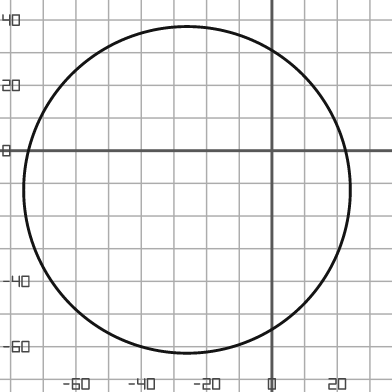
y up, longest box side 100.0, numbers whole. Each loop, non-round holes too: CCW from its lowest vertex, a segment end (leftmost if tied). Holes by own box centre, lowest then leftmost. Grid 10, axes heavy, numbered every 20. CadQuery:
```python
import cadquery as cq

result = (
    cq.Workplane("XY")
    .moveTo(-26.0, -12.0)
    .circle(50.0)
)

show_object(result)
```